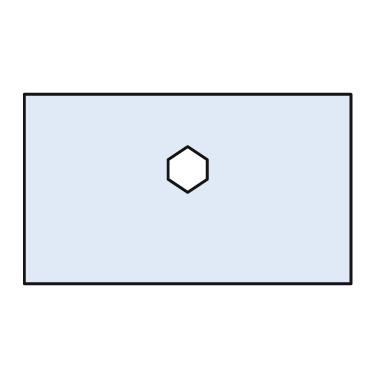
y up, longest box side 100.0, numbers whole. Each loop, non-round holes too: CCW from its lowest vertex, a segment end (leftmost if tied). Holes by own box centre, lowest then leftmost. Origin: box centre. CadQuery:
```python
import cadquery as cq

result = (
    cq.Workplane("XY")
    .moveTo(-50.0, -29.0)
    .lineTo(50.0, -29.0)
    .lineTo(50.0, 29.0)
    .lineTo(-50.0, 29.0)
    .close()
    .moveTo(0.0, -1.0)
    .lineTo(6.0, 3.0)
    .lineTo(6.0, 9.0)
    .lineTo(0.0, 13.0)
    .lineTo(-6.0, 9.0)
    .lineTo(-6.0, 3.0)
    .close()
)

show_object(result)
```